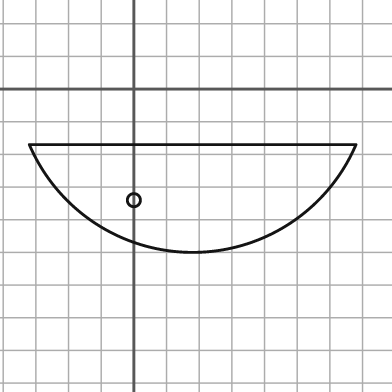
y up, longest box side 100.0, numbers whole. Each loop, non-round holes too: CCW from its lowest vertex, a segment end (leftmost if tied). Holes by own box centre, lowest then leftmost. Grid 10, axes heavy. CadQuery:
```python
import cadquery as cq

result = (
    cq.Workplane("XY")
    .moveTo(-32.0, -17.0)
    .threePointArc((18.0, -50.0), (68.0, -17.0))
    .close()
    .moveTo(0.0, -34.0)
    .circle(2.0)
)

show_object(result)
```